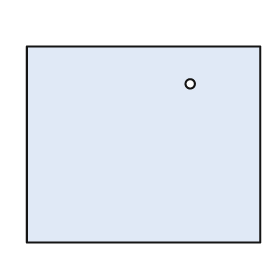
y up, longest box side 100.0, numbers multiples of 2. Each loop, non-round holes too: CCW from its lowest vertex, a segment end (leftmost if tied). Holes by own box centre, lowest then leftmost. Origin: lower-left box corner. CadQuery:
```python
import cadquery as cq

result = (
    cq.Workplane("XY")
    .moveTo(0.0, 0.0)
    .lineTo(100.0, 0.0)
    .lineTo(100.0, 84.0)
    .lineTo(0.0, 84.0)
    .close()
    .moveTo(70.0, 68.0)
    .circle(2.0)
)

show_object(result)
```